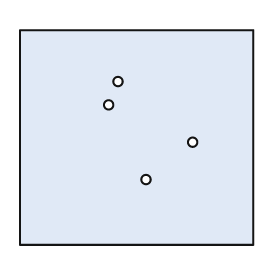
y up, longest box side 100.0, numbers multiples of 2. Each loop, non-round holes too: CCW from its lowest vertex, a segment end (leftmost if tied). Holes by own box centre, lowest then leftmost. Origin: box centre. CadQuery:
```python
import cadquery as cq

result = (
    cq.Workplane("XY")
    .moveTo(-50.0, -46.0)
    .lineTo(50.0, -46.0)
    .lineTo(50.0, 46.0)
    .lineTo(-50.0, 46.0)
    .close()
    .moveTo(4.0, -18.0)
    .circle(2.0)
    .moveTo(24.0, -2.0)
    .circle(2.0)
    .moveTo(-12.0, 14.0)
    .circle(2.0)
    .moveTo(-8.0, 24.0)
    .circle(2.0)
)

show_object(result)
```